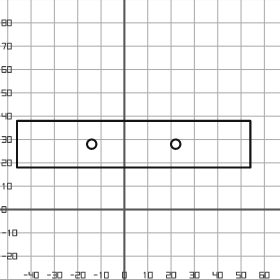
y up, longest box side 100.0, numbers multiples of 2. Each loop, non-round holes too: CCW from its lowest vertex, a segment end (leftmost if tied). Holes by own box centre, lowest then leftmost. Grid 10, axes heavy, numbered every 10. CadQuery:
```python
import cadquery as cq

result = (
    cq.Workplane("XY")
    .moveTo(-46.0, 18.0)
    .lineTo(54.0, 18.0)
    .lineTo(54.0, 38.0)
    .lineTo(-46.0, 38.0)
    .close()
    .moveTo(-14.0, 28.0)
    .circle(2.0)
    .moveTo(22.0, 28.0)
    .circle(2.0)
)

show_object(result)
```